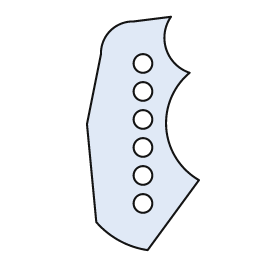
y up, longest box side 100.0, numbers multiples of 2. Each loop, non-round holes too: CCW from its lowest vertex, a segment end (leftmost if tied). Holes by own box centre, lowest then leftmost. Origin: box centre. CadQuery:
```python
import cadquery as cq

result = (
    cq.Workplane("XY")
    .moveTo(2.0, -50.0)
    .lineTo(24.0, -20.0)
    .threePointArc((10.0, 2.0), (20.0, 26.0))
    .threePointArc((10.0, 36.0), (12.0, 50.0))
    .lineTo(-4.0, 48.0)
    .threePointArc((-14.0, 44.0), (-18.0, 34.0))
    .lineTo(-24.0, 4.0)
    .lineTo(-20.0, -38.0)
    .threePointArc((-10.0, -46.0), (2.0, -50.0))
    .close()
    .moveTo(0.0, -30.0)
    .circle(4.0)
    .moveTo(0.0, -18.0)
    .circle(4.0)
    .moveTo(0.0, -6.0)
    .circle(4.0)
    .moveTo(0.0, 6.0)
    .circle(4.0)
    .moveTo(0.0, 18.0)
    .circle(4.0)
    .moveTo(0.0, 30.0)
    .circle(4.0)
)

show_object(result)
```